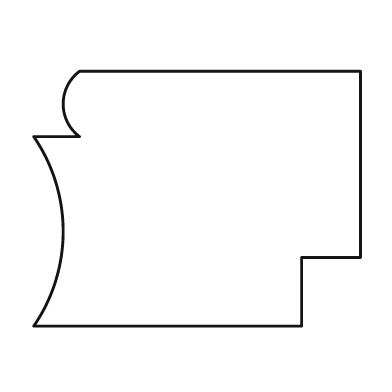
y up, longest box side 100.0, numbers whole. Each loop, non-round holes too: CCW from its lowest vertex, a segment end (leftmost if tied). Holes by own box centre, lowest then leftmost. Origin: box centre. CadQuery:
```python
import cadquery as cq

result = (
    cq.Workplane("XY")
    .moveTo(-50.0, -39.0)
    .lineTo(32.0, -39.0)
    .lineTo(32.0, -18.0)
    .lineTo(50.0, -18.0)
    .lineTo(50.0, 39.0)
    .lineTo(-36.0, 39.0)
    .threePointArc((-41.0, 29.0), (-36.0, 19.0))
    .lineTo(-50.0, 19.0)
    .threePointArc((-41.0, -10.0), (-50.0, -39.0))
    .close()
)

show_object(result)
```